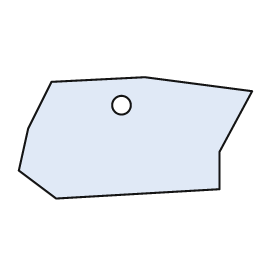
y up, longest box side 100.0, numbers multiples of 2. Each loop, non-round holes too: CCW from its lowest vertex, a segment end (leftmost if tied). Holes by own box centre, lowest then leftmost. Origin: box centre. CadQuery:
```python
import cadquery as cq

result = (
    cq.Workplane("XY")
    .moveTo(-34.0, -26.0)
    .lineTo(36.0, -22.0)
    .lineTo(36.0, -6.0)
    .lineTo(50.0, 20.0)
    .lineTo(4.0, 26.0)
    .lineTo(-36.0, 24.0)
    .lineTo(-46.0, 4.0)
    .lineTo(-50.0, -14.0)
    .close()
    .moveTo(-6.0, 14.0)
    .circle(4.0)
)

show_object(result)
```